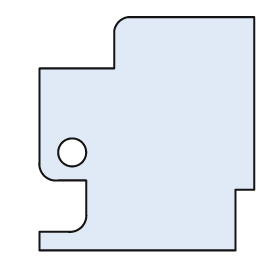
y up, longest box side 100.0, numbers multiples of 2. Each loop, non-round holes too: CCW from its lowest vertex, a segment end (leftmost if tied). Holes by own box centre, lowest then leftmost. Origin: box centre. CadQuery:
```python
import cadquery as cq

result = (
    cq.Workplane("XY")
    .moveTo(-46.0, -50.0)
    .lineTo(38.0, -50.0)
    .lineTo(38.0, -24.0)
    .lineTo(46.0, -24.0)
    .lineTo(46.0, 50.0)
    .lineTo(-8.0, 50.0)
    .threePointArc((-12.0, 48.0), (-14.0, 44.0))
    .lineTo(-14.0, 28.0)
    .lineTo(-46.0, 28.0)
    .lineTo(-46.0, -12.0)
    .threePointArc((-44.0, -18.0), (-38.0, -20.0))
    .lineTo(-26.0, -20.0)
    .lineTo(-26.0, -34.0)
    .threePointArc((-28.0, -40.0), (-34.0, -42.0))
    .lineTo(-46.0, -42.0)
    .close()
    .moveTo(-32.0, -8.0)
    .circle(6.0)
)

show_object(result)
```